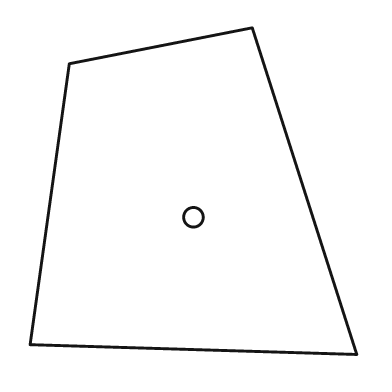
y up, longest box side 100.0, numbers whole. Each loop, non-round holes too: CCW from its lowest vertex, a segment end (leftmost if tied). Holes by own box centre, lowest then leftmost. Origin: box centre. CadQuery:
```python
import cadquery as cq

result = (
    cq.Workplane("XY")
    .moveTo(50.0, -50.0)
    .lineTo(18.0, 50.0)
    .lineTo(-38.0, 39.0)
    .lineTo(-50.0, -47.0)
    .close()
    .moveTo(0.0, -8.0)
    .circle(3.0)
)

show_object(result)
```